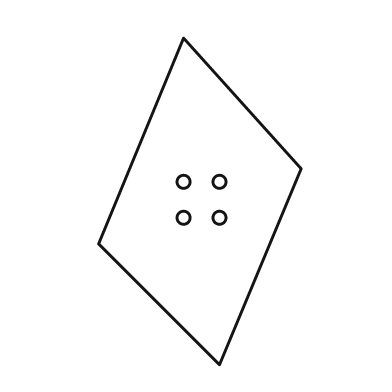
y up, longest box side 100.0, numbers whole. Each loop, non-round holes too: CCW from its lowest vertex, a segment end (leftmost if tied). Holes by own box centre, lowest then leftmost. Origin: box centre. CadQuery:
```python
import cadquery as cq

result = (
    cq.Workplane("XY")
    .moveTo(6.0, -50.0)
    .lineTo(31.0, 10.0)
    .lineTo(-5.0, 50.0)
    .lineTo(-31.0, -13.0)
    .close()
    .moveTo(-5.0, -5.0)
    .circle(2.0)
    .moveTo(6.0, -5.0)
    .circle(2.0)
    .moveTo(-5.0, 6.0)
    .circle(2.0)
    .moveTo(6.0, 6.0)
    .circle(2.0)
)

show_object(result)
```